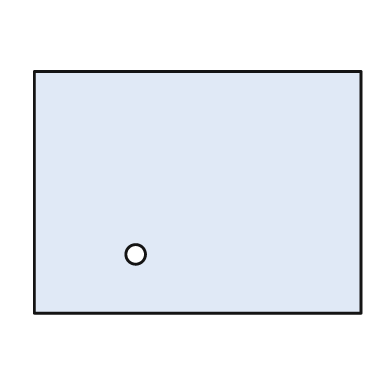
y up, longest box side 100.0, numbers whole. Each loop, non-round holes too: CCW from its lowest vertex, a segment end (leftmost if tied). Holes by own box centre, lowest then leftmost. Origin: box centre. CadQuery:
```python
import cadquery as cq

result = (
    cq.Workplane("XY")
    .moveTo(-50.0, -37.0)
    .lineTo(50.0, -37.0)
    .lineTo(50.0, 37.0)
    .lineTo(-50.0, 37.0)
    .close()
    .moveTo(-19.0, -19.0)
    .circle(3.0)
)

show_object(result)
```